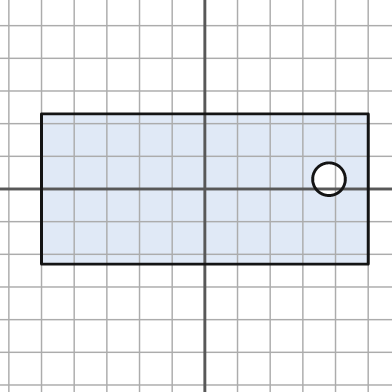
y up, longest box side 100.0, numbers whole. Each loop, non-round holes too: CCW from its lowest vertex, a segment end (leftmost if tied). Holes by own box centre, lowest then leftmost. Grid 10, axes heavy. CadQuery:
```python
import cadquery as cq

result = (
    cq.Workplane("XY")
    .moveTo(-50.0, -23.0)
    .lineTo(50.0, -23.0)
    .lineTo(50.0, 23.0)
    .lineTo(-50.0, 23.0)
    .close()
    .moveTo(38.0, 3.0)
    .circle(5.0)
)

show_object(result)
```